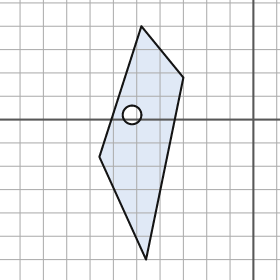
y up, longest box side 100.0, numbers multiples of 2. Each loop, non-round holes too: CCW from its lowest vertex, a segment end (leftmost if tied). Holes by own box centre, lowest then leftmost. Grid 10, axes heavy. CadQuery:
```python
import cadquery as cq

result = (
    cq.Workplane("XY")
    .moveTo(-46.0, -60.0)
    .lineTo(-30.0, 18.0)
    .lineTo(-48.0, 40.0)
    .lineTo(-66.0, -16.0)
    .close()
    .moveTo(-52.0, 2.0)
    .circle(4.0)
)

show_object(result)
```